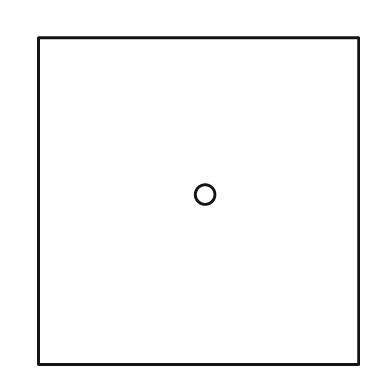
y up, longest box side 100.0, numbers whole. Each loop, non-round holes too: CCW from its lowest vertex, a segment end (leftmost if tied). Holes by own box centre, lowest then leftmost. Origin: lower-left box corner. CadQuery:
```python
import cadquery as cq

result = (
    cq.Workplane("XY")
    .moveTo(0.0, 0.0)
    .lineTo(98.0, 0.0)
    .lineTo(98.0, 100.0)
    .lineTo(0.0, 100.0)
    .close()
    .moveTo(51.0, 52.0)
    .circle(3.0)
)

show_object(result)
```